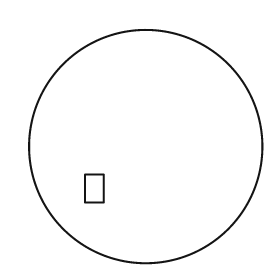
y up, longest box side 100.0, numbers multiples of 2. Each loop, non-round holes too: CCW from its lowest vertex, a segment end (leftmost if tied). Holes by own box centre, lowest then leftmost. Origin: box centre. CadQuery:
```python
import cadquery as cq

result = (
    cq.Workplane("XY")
    .moveTo(0.0, 0.0)
    .circle(50.0)
    .moveTo(-26.0, -24.0)
    .lineTo(-18.0, -24.0)
    .lineTo(-18.0, -12.0)
    .lineTo(-26.0, -12.0)
    .close()
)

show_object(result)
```